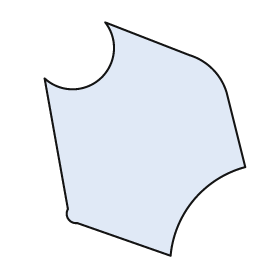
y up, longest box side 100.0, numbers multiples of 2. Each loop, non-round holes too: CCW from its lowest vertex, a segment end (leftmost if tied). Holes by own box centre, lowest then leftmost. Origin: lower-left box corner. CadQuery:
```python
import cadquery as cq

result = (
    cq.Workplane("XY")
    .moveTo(54.0, 0.0)
    .threePointArc((64.0, 24.0), (86.0, 38.0))
    .lineTo(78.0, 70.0)
    .threePointArc((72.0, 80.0), (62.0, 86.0))
    .lineTo(26.0, 100.0)
    .threePointArc((24.0, 76.0), (0.0, 76.0))
    .lineTo(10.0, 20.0)
    .threePointArc((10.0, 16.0), (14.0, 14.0))
    .close()
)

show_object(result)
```